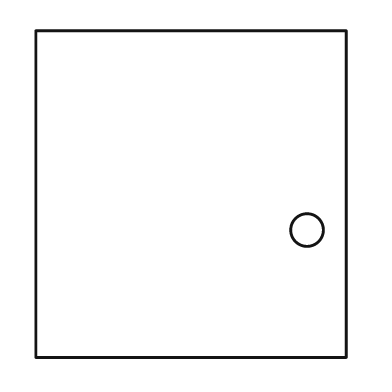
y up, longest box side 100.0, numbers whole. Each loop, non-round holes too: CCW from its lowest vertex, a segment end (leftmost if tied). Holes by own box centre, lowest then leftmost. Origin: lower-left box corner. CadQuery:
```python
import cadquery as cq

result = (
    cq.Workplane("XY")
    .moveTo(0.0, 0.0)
    .lineTo(95.0, 0.0)
    .lineTo(95.0, 100.0)
    .lineTo(0.0, 100.0)
    .close()
    .moveTo(83.0, 39.0)
    .circle(5.0)
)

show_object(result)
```